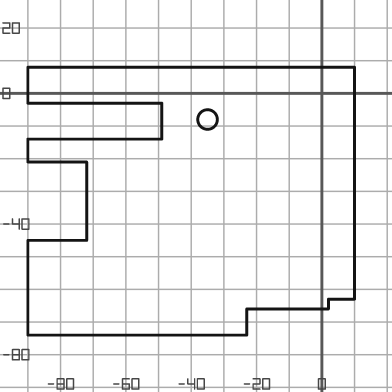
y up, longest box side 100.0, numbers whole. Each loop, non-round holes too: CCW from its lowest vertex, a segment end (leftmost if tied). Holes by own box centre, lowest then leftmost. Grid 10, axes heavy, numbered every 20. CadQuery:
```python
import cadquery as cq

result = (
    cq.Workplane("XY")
    .moveTo(-90.0, -74.0)
    .lineTo(-23.0, -74.0)
    .lineTo(-23.0, -66.0)
    .lineTo(2.0, -66.0)
    .lineTo(2.0, -63.0)
    .lineTo(10.0, -63.0)
    .lineTo(10.0, 8.0)
    .lineTo(-90.0, 8.0)
    .lineTo(-90.0, -3.0)
    .lineTo(-49.0, -3.0)
    .lineTo(-49.0, -14.0)
    .lineTo(-90.0, -14.0)
    .lineTo(-90.0, -21.0)
    .lineTo(-72.0, -21.0)
    .lineTo(-72.0, -45.0)
    .lineTo(-90.0, -45.0)
    .close()
    .moveTo(-35.0, -8.0)
    .circle(3.0)
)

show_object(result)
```